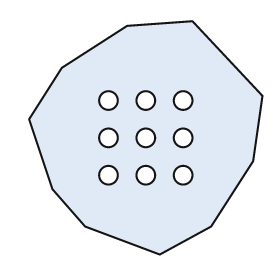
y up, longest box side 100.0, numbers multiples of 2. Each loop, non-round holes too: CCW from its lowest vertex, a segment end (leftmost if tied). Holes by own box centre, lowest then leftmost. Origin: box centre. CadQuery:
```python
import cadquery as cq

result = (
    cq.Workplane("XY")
    .moveTo(6.0, -50.0)
    .lineTo(28.0, -38.0)
    .lineTo(46.0, -10.0)
    .lineTo(50.0, 18.0)
    .lineTo(20.0, 50.0)
    .lineTo(-8.0, 48.0)
    .lineTo(-36.0, 30.0)
    .lineTo(-50.0, 8.0)
    .lineTo(-40.0, -22.0)
    .lineTo(-26.0, -38.0)
    .close()
    .moveTo(-16.0, -16.0)
    .circle(4.0)
    .moveTo(0.0, -16.0)
    .circle(4.0)
    .moveTo(16.0, -16.0)
    .circle(4.0)
    .moveTo(-16.0, 0.0)
    .circle(4.0)
    .moveTo(0.0, 0.0)
    .circle(4.0)
    .moveTo(16.0, 0.0)
    .circle(4.0)
    .moveTo(-16.0, 16.0)
    .circle(4.0)
    .moveTo(0.0, 16.0)
    .circle(4.0)
    .moveTo(16.0, 16.0)
    .circle(4.0)
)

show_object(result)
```